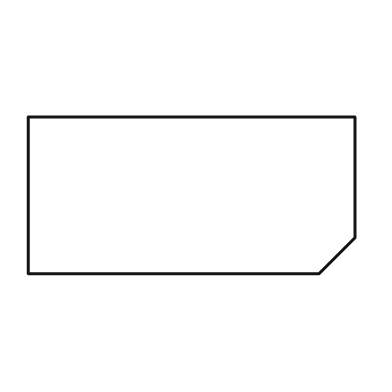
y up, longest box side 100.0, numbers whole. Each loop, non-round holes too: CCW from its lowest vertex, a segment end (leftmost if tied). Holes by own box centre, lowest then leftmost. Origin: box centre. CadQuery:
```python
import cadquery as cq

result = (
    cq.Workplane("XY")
    .moveTo(-50.0, -24.0)
    .lineTo(39.0, -24.0)
    .lineTo(50.0, -13.0)
    .lineTo(50.0, 24.0)
    .lineTo(-50.0, 24.0)
    .close()
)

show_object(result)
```